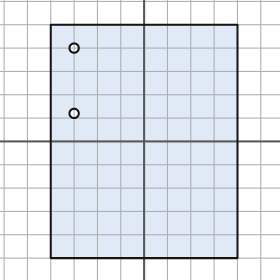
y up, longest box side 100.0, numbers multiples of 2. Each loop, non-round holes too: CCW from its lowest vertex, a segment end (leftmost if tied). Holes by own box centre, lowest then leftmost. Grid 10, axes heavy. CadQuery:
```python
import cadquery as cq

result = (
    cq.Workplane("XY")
    .moveTo(-40.0, -50.0)
    .lineTo(40.0, -50.0)
    .lineTo(40.0, 50.0)
    .lineTo(-40.0, 50.0)
    .close()
    .moveTo(-30.0, 12.0)
    .circle(2.0)
    .moveTo(-30.0, 40.0)
    .circle(2.0)
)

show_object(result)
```